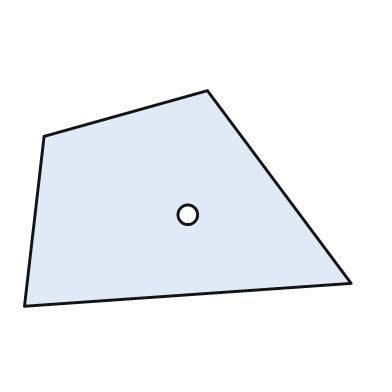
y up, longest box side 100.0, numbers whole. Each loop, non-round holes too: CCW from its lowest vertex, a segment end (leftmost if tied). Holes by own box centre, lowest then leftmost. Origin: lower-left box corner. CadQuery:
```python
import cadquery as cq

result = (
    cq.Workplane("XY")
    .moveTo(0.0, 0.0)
    .lineTo(100.0, 7.0)
    .lineTo(56.0, 66.0)
    .lineTo(6.0, 52.0)
    .close()
    .moveTo(50.0, 28.0)
    .circle(3.0)
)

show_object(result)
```